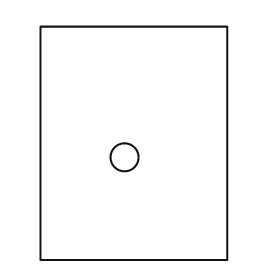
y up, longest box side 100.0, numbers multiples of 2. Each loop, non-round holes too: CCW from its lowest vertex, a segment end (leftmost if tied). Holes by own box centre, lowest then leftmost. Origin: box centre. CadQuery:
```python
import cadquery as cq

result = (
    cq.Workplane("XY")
    .moveTo(-40.0, -50.0)
    .lineTo(40.0, -50.0)
    .lineTo(40.0, 50.0)
    .lineTo(-40.0, 50.0)
    .close()
    .moveTo(-4.0, -6.0)
    .circle(6.0)
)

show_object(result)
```